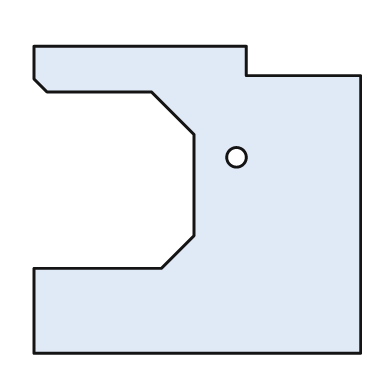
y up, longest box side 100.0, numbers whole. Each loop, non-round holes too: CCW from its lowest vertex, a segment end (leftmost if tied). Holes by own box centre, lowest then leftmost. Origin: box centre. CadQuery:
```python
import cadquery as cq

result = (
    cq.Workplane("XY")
    .moveTo(-50.0, -47.0)
    .lineTo(50.0, -47.0)
    .lineTo(50.0, 38.0)
    .lineTo(15.0, 38.0)
    .lineTo(15.0, 47.0)
    .lineTo(-50.0, 47.0)
    .lineTo(-50.0, 37.0)
    .lineTo(-46.0, 33.0)
    .lineTo(-14.0, 33.0)
    .lineTo(-1.0, 20.0)
    .lineTo(-1.0, -11.0)
    .lineTo(-11.0, -21.0)
    .lineTo(-50.0, -21.0)
    .close()
    .moveTo(12.0, 13.0)
    .circle(3.0)
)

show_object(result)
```